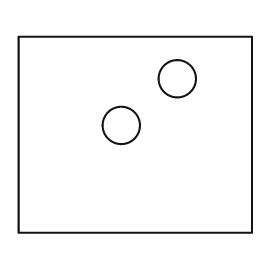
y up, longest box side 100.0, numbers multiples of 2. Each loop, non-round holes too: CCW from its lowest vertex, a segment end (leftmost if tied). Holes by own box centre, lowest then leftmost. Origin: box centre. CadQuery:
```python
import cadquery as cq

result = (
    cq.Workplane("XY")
    .moveTo(-50.0, -42.0)
    .lineTo(50.0, -42.0)
    .lineTo(50.0, 42.0)
    .lineTo(-50.0, 42.0)
    .close()
    .moveTo(-6.0, 4.0)
    .circle(8.0)
    .moveTo(18.0, 24.0)
    .circle(8.0)
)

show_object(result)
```